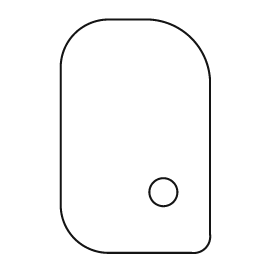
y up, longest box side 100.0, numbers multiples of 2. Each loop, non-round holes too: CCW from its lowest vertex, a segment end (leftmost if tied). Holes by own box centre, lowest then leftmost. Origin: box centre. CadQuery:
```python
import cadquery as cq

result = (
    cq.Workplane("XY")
    .moveTo(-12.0, -50.0)
    .lineTo(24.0, -50.0)
    .threePointArc((30.0, -48.0), (32.0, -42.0))
    .lineTo(32.0, 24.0)
    .threePointArc((24.0, 42.0), (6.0, 50.0))
    .lineTo(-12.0, 50.0)
    .threePointArc((-26.0, 44.0), (-32.0, 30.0))
    .lineTo(-32.0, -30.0)
    .threePointArc((-26.0, -44.0), (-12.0, -50.0))
    .close()
    .moveTo(12.0, -24.0)
    .circle(6.0)
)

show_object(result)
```